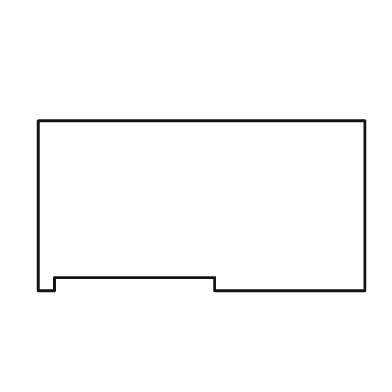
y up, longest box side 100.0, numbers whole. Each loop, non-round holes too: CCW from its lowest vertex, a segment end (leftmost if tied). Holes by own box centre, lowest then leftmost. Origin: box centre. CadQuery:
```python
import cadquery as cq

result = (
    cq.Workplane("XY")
    .moveTo(-50.0, -26.0)
    .lineTo(-45.0, -26.0)
    .lineTo(-45.0, -22.0)
    .lineTo(4.0, -22.0)
    .lineTo(4.0, -26.0)
    .lineTo(50.0, -26.0)
    .lineTo(50.0, 26.0)
    .lineTo(-50.0, 26.0)
    .close()
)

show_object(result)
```